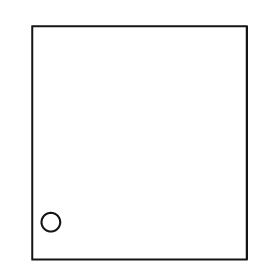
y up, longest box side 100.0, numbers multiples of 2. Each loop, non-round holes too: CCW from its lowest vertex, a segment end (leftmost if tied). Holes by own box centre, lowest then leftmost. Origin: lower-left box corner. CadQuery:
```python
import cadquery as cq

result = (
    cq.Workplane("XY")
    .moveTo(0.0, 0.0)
    .lineTo(92.0, 0.0)
    .lineTo(92.0, 100.0)
    .lineTo(0.0, 100.0)
    .close()
    .moveTo(8.0, 16.0)
    .circle(4.0)
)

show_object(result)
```